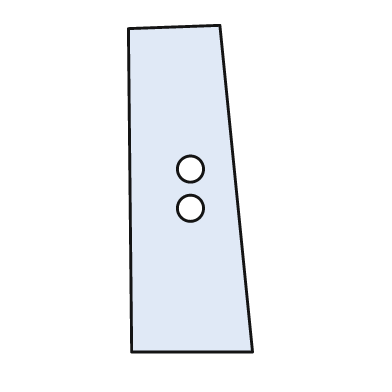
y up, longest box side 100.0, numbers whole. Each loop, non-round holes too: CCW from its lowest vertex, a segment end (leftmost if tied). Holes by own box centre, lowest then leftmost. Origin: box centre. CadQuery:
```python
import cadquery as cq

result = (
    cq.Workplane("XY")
    .moveTo(-18.0, -50.0)
    .lineTo(19.0, -50.0)
    .lineTo(9.0, 50.0)
    .lineTo(-19.0, 49.0)
    .close()
    .moveTo(0.0, -6.0)
    .circle(4.0)
    .moveTo(0.0, 6.0)
    .circle(4.0)
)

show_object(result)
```